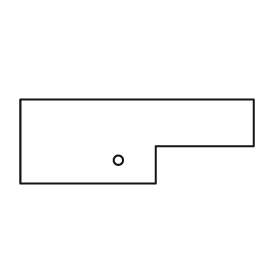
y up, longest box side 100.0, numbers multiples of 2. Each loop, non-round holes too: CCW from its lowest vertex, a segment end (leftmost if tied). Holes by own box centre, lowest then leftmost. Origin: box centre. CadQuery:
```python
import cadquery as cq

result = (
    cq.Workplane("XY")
    .moveTo(-50.0, -18.0)
    .lineTo(8.0, -18.0)
    .lineTo(8.0, -2.0)
    .lineTo(50.0, -2.0)
    .lineTo(50.0, 18.0)
    .lineTo(-50.0, 18.0)
    .close()
    .moveTo(-8.0, -8.0)
    .circle(2.0)
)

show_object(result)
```